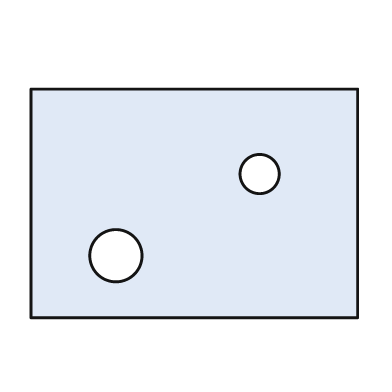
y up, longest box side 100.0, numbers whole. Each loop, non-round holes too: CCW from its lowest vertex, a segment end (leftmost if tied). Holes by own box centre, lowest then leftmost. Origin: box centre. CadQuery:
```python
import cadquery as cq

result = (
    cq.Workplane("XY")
    .moveTo(-50.0, -35.0)
    .lineTo(50.0, -35.0)
    .lineTo(50.0, 35.0)
    .lineTo(-50.0, 35.0)
    .close()
    .moveTo(-24.0, -16.0)
    .circle(8.0)
    .moveTo(20.0, 9.0)
    .circle(6.0)
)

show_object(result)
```